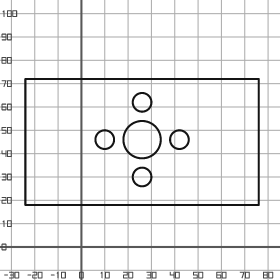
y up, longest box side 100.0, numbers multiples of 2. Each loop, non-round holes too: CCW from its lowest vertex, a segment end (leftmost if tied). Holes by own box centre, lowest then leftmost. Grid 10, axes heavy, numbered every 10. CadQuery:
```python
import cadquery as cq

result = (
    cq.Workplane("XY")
    .moveTo(-24.0, 18.0)
    .lineTo(76.0, 18.0)
    .lineTo(76.0, 72.0)
    .lineTo(-24.0, 72.0)
    .close()
    .moveTo(26.0, 30.0)
    .circle(4.0)
    .moveTo(10.0, 46.0)
    .circle(4.0)
    .moveTo(26.0, 46.0)
    .circle(8.0)
    .moveTo(42.0, 46.0)
    .circle(4.0)
    .moveTo(26.0, 62.0)
    .circle(4.0)
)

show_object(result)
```